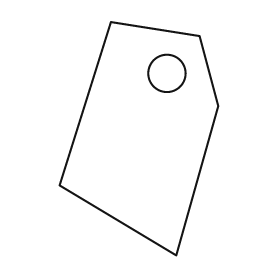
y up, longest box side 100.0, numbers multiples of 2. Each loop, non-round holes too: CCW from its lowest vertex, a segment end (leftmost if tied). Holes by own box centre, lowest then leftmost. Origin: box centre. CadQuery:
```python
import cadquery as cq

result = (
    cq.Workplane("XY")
    .moveTo(16.0, -50.0)
    .lineTo(34.0, 14.0)
    .lineTo(26.0, 44.0)
    .lineTo(-12.0, 50.0)
    .lineTo(-34.0, -20.0)
    .close()
    .moveTo(12.0, 28.0)
    .circle(8.0)
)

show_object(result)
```